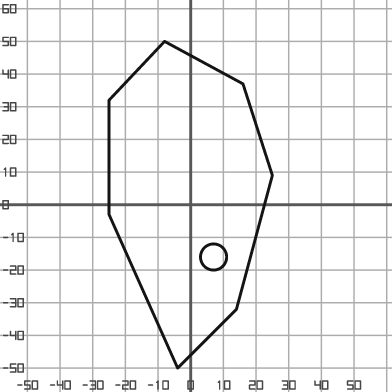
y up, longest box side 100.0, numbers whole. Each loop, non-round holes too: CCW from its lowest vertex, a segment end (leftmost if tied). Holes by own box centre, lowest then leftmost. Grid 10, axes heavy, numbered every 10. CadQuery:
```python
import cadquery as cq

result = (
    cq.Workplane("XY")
    .moveTo(-4.0, -50.0)
    .lineTo(14.0, -32.0)
    .lineTo(25.0, 9.0)
    .lineTo(16.0, 37.0)
    .lineTo(-8.0, 50.0)
    .lineTo(-25.0, 32.0)
    .lineTo(-25.0, -3.0)
    .close()
    .moveTo(7.0, -16.0)
    .circle(4.0)
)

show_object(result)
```